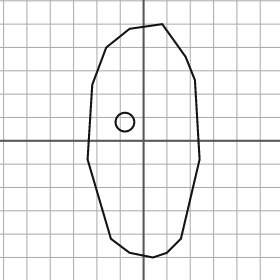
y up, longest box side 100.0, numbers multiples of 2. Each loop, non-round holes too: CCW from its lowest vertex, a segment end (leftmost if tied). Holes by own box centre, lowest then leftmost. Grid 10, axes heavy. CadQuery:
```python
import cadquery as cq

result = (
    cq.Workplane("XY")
    .moveTo(4.0, -50.0)
    .lineTo(10.0, -48.0)
    .lineTo(16.0, -42.0)
    .lineTo(24.0, -8.0)
    .lineTo(22.0, 26.0)
    .lineTo(18.0, 36.0)
    .lineTo(8.0, 50.0)
    .lineTo(-6.0, 48.0)
    .lineTo(-16.0, 40.0)
    .lineTo(-22.0, 24.0)
    .lineTo(-24.0, -8.0)
    .lineTo(-14.0, -42.0)
    .lineTo(-6.0, -48.0)
    .close()
    .moveTo(-8.0, 8.0)
    .circle(4.0)
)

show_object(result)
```